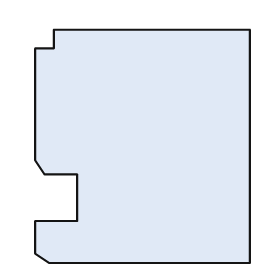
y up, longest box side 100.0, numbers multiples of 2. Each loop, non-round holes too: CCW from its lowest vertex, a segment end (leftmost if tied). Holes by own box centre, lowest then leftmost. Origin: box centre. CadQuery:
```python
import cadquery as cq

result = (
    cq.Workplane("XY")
    .moveTo(-40.0, -50.0)
    .lineTo(46.0, -50.0)
    .lineTo(46.0, 50.0)
    .lineTo(-38.0, 50.0)
    .lineTo(-38.0, 42.0)
    .lineTo(-46.0, 42.0)
    .lineTo(-46.0, -6.0)
    .lineTo(-42.0, -12.0)
    .lineTo(-28.0, -12.0)
    .lineTo(-28.0, -32.0)
    .lineTo(-46.0, -32.0)
    .lineTo(-46.0, -46.0)
    .close()
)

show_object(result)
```